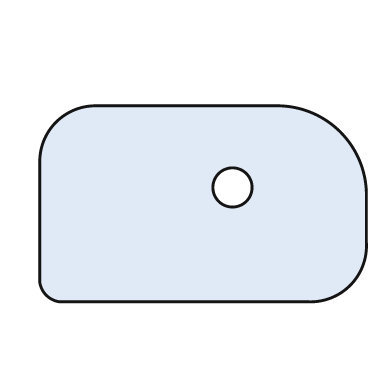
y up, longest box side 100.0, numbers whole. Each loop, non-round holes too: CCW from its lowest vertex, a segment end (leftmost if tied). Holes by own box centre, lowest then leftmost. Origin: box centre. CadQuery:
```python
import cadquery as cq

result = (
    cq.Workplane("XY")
    .moveTo(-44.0, -30.0)
    .lineTo(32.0, -30.0)
    .threePointArc((45.0, -25.0), (50.0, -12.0))
    .lineTo(50.0, 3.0)
    .threePointArc((42.0, 22.0), (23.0, 30.0))
    .lineTo(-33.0, 30.0)
    .threePointArc((-45.0, 25.0), (-50.0, 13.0))
    .lineTo(-50.0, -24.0)
    .threePointArc((-48.0, -28.0), (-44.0, -30.0))
    .close()
    .moveTo(9.0, 5.0)
    .circle(6.0)
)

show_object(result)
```